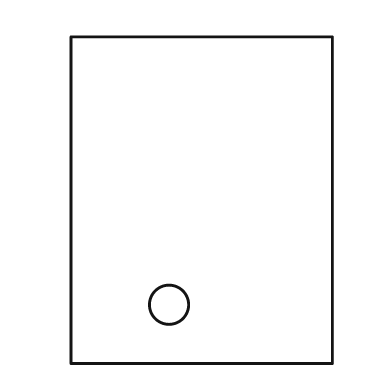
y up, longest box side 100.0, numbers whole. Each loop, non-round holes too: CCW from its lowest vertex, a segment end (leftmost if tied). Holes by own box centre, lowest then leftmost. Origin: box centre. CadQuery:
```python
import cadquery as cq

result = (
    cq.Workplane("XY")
    .moveTo(-40.0, -50.0)
    .lineTo(40.0, -50.0)
    .lineTo(40.0, 50.0)
    .lineTo(-40.0, 50.0)
    .close()
    .moveTo(-10.0, -32.0)
    .circle(6.0)
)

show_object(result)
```